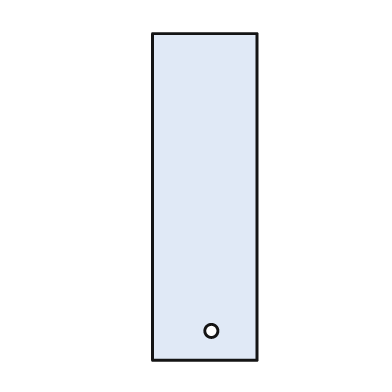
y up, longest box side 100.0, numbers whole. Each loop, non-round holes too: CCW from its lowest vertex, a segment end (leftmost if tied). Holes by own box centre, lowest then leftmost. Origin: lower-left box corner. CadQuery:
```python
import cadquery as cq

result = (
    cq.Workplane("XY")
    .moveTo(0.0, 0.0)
    .lineTo(32.0, 0.0)
    .lineTo(32.0, 100.0)
    .lineTo(0.0, 100.0)
    .close()
    .moveTo(18.0, 9.0)
    .circle(2.0)
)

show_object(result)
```